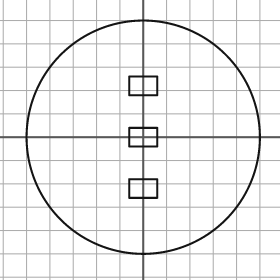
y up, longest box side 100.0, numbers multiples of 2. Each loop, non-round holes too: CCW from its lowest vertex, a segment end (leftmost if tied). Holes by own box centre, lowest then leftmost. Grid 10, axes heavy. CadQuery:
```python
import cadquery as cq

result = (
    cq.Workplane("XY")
    .moveTo(0.0, 0.0)
    .circle(50.0)
    .moveTo(-6.0, -26.0)
    .lineTo(6.0, -26.0)
    .lineTo(6.0, -18.0)
    .lineTo(-6.0, -18.0)
    .close()
    .moveTo(-6.0, -4.0)
    .lineTo(6.0, -4.0)
    .lineTo(6.0, 4.0)
    .lineTo(-6.0, 4.0)
    .close()
    .moveTo(-6.0, 18.0)
    .lineTo(6.0, 18.0)
    .lineTo(6.0, 26.0)
    .lineTo(-6.0, 26.0)
    .close()
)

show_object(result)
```